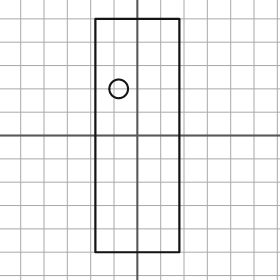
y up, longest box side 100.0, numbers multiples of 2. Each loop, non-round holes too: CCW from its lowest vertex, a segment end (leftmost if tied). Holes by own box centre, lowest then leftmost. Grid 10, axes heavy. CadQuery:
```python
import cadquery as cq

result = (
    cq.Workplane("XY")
    .moveTo(-18.0, -50.0)
    .lineTo(18.0, -50.0)
    .lineTo(18.0, 50.0)
    .lineTo(-18.0, 50.0)
    .close()
    .moveTo(-8.0, 20.0)
    .circle(4.0)
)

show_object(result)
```